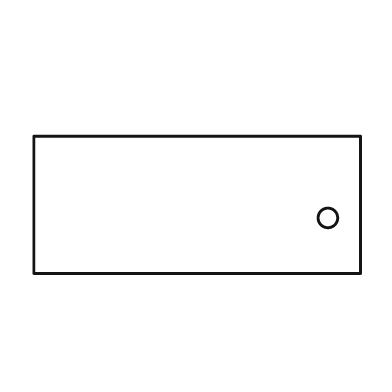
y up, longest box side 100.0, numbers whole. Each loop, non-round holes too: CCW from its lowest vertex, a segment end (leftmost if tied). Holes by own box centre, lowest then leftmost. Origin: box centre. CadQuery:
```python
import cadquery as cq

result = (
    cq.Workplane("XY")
    .moveTo(-50.0, -21.0)
    .lineTo(50.0, -21.0)
    .lineTo(50.0, 21.0)
    .lineTo(-50.0, 21.0)
    .close()
    .moveTo(40.0, -4.0)
    .circle(3.0)
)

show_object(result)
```